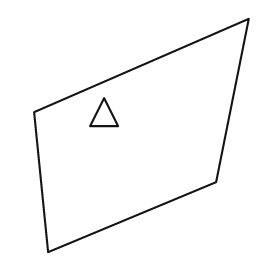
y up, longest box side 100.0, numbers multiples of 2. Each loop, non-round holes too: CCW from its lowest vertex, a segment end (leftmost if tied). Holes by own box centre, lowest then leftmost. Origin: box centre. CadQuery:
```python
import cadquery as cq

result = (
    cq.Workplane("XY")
    .moveTo(-40.0, -50.0)
    .lineTo(32.0, -20.0)
    .lineTo(46.0, 50.0)
    .lineTo(-46.0, 10.0)
    .close()
    .moveTo(-22.0, 4.0)
    .lineTo(-10.0, 4.0)
    .lineTo(-16.0, 16.0)
    .close()
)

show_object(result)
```